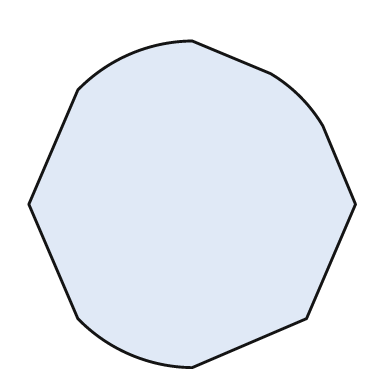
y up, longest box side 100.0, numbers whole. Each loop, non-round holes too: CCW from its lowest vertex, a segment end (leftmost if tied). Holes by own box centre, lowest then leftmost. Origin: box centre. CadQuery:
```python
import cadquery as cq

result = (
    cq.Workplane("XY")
    .moveTo(0.0, -50.0)
    .lineTo(35.0, -35.0)
    .lineTo(50.0, 0.0)
    .lineTo(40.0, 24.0)
    .threePointArc((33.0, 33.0), (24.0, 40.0))
    .lineTo(0.0, 50.0)
    .threePointArc((-19.0, 46.0), (-35.0, 35.0))
    .lineTo(-50.0, 0.0)
    .lineTo(-35.0, -35.0)
    .threePointArc((-19.0, -46.0), (0.0, -50.0))
    .close()
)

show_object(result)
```